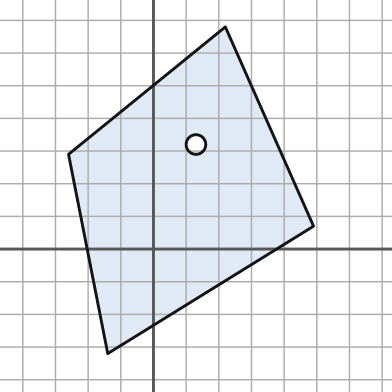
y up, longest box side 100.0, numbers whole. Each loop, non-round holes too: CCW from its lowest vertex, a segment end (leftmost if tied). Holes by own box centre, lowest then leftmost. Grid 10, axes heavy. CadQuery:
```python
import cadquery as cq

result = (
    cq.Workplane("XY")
    .moveTo(-14.0, -32.0)
    .lineTo(49.0, 7.0)
    .lineTo(22.0, 68.0)
    .lineTo(-26.0, 29.0)
    .close()
    .moveTo(13.0, 32.0)
    .circle(3.0)
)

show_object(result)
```